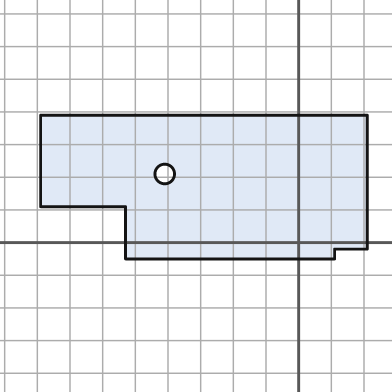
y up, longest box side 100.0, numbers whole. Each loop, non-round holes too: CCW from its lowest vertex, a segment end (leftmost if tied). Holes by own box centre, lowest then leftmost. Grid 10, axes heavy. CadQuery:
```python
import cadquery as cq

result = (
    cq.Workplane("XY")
    .moveTo(-53.0, -5.0)
    .lineTo(11.0, -5.0)
    .lineTo(11.0, -2.0)
    .lineTo(21.0, -2.0)
    .lineTo(21.0, 39.0)
    .lineTo(-79.0, 39.0)
    .lineTo(-79.0, 11.0)
    .lineTo(-53.0, 11.0)
    .close()
    .moveTo(-41.0, 21.0)
    .circle(3.0)
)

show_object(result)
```